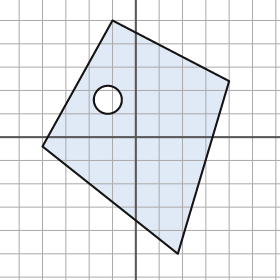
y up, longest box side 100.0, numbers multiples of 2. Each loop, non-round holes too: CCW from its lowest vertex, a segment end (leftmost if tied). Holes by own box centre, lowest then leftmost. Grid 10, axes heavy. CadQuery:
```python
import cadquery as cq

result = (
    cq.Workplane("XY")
    .moveTo(18.0, -50.0)
    .lineTo(40.0, 24.0)
    .lineTo(-10.0, 50.0)
    .lineTo(-40.0, -4.0)
    .close()
    .moveTo(-12.0, 16.0)
    .circle(6.0)
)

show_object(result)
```